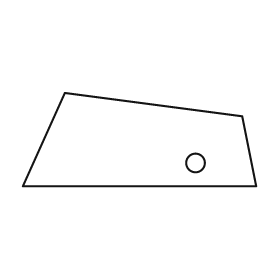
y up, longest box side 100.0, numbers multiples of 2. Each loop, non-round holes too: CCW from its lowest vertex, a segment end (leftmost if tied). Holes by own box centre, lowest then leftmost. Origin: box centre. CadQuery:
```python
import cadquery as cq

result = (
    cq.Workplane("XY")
    .moveTo(-50.0, -20.0)
    .lineTo(50.0, -20.0)
    .lineTo(44.0, 10.0)
    .lineTo(-32.0, 20.0)
    .close()
    .moveTo(24.0, -10.0)
    .circle(4.0)
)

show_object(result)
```